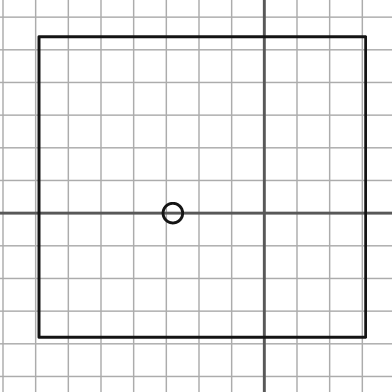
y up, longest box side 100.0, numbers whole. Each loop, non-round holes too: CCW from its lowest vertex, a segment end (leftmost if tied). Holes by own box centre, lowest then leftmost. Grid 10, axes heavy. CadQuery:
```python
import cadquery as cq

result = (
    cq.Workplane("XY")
    .moveTo(-69.0, -38.0)
    .lineTo(31.0, -38.0)
    .lineTo(31.0, 54.0)
    .lineTo(-69.0, 54.0)
    .close()
    .moveTo(-28.0, 0.0)
    .circle(3.0)
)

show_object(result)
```